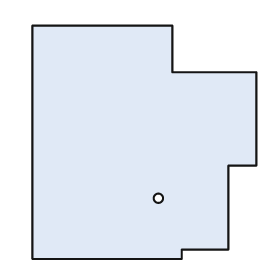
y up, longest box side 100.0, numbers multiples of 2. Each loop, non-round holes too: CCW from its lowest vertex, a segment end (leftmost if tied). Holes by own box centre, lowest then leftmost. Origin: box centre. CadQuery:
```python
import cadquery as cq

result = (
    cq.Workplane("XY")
    .moveTo(-48.0, -50.0)
    .lineTo(16.0, -50.0)
    .lineTo(16.0, -46.0)
    .lineTo(36.0, -46.0)
    .lineTo(36.0, -10.0)
    .lineTo(48.0, -10.0)
    .lineTo(48.0, 30.0)
    .lineTo(12.0, 30.0)
    .lineTo(12.0, 50.0)
    .lineTo(-48.0, 50.0)
    .close()
    .moveTo(6.0, -24.0)
    .circle(2.0)
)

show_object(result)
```